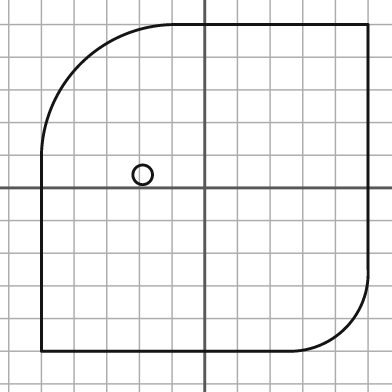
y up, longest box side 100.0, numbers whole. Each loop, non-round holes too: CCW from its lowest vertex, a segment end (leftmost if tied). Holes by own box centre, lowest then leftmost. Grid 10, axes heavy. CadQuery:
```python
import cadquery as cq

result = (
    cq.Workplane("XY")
    .moveTo(-50.0, -50.0)
    .lineTo(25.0, -50.0)
    .threePointArc((43.0, -43.0), (50.0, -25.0))
    .lineTo(50.0, 50.0)
    .lineTo(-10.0, 50.0)
    .threePointArc((-38.0, 38.0), (-50.0, 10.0))
    .close()
    .moveTo(-19.0, 4.0)
    .circle(3.0)
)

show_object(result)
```